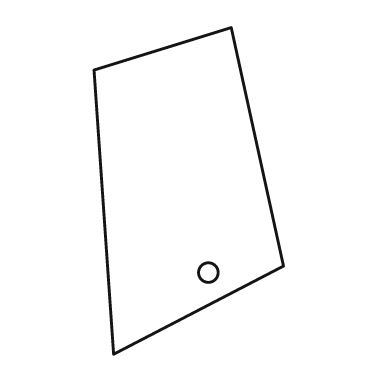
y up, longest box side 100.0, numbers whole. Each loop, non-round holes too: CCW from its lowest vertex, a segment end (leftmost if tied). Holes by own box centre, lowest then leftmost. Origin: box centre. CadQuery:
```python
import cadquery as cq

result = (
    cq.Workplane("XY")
    .moveTo(-23.0, -50.0)
    .lineTo(29.0, -23.0)
    .lineTo(13.0, 50.0)
    .lineTo(-29.0, 37.0)
    .close()
    .moveTo(6.0, -25.0)
    .circle(3.0)
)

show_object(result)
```